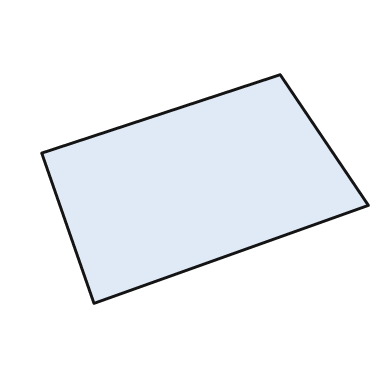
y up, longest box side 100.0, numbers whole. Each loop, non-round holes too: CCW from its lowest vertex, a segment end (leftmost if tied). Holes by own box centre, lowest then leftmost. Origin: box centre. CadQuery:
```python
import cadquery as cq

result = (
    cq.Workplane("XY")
    .moveTo(-34.0, -35.0)
    .lineTo(50.0, -5.0)
    .lineTo(23.0, 35.0)
    .lineTo(-50.0, 11.0)
    .close()
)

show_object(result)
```